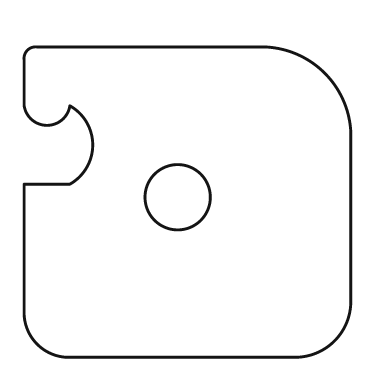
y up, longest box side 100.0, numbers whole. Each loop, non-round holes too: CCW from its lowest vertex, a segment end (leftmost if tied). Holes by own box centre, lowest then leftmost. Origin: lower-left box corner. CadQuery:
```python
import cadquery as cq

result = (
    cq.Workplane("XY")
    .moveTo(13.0, 0.0)
    .lineTo(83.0, 0.0)
    .threePointArc((95.0, 5.0), (100.0, 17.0))
    .lineTo(100.0, 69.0)
    .threePointArc((92.0, 87.0), (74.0, 95.0))
    .lineTo(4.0, 95.0)
    .threePointArc((1.0, 94.0), (0.0, 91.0))
    .lineTo(0.0, 77.0)
    .threePointArc((7.0, 71.0), (14.0, 77.0))
    .threePointArc((21.0, 65.0), (14.0, 53.0))
    .lineTo(0.0, 53.0)
    .lineTo(0.0, 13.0)
    .threePointArc((4.0, 4.0), (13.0, 0.0))
    .close()
    .moveTo(47.0, 49.0)
    .circle(10.0)
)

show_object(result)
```